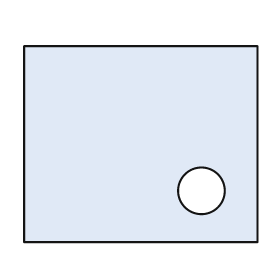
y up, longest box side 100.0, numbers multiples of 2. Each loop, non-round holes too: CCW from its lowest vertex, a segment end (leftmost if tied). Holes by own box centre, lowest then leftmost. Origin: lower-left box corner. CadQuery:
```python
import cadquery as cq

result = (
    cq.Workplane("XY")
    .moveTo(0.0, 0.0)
    .lineTo(100.0, 0.0)
    .lineTo(100.0, 84.0)
    .lineTo(0.0, 84.0)
    .close()
    .moveTo(76.0, 22.0)
    .circle(10.0)
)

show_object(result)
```